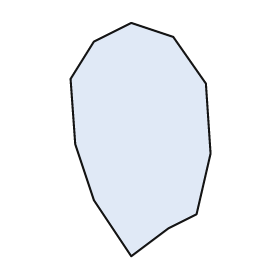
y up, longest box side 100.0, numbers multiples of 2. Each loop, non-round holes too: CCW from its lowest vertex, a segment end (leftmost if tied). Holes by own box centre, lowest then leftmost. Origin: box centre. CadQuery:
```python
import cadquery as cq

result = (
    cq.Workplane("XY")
    .moveTo(-4.0, -50.0)
    .lineTo(12.0, -38.0)
    .lineTo(24.0, -32.0)
    .lineTo(30.0, -6.0)
    .lineTo(28.0, 24.0)
    .lineTo(14.0, 44.0)
    .lineTo(-4.0, 50.0)
    .lineTo(-20.0, 42.0)
    .lineTo(-30.0, 26.0)
    .lineTo(-28.0, -2.0)
    .lineTo(-20.0, -26.0)
    .close()
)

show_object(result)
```